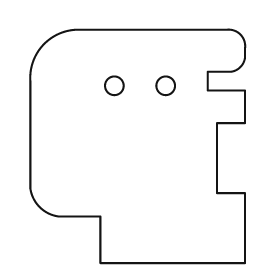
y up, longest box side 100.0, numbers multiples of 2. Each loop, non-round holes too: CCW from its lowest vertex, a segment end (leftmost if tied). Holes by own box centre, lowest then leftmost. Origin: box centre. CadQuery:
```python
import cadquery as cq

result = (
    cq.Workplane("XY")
    .moveTo(-16.0, -50.0)
    .lineTo(46.0, -50.0)
    .lineTo(46.0, -20.0)
    .lineTo(34.0, -20.0)
    .lineTo(34.0, 10.0)
    .lineTo(46.0, 10.0)
    .lineTo(46.0, 24.0)
    .lineTo(30.0, 24.0)
    .lineTo(30.0, 32.0)
    .lineTo(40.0, 32.0)
    .threePointArc((44.0, 34.0), (46.0, 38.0))
    .lineTo(46.0, 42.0)
    .threePointArc((44.0, 48.0), (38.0, 50.0))
    .lineTo(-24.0, 50.0)
    .threePointArc((-40.0, 44.0), (-46.0, 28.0))
    .lineTo(-46.0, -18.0)
    .threePointArc((-42.0, -26.0), (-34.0, -30.0))
    .lineTo(-16.0, -30.0)
    .close()
    .moveTo(-10.0, 26.0)
    .circle(4.0)
    .moveTo(12.0, 26.0)
    .circle(4.0)
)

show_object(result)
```